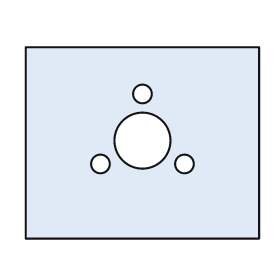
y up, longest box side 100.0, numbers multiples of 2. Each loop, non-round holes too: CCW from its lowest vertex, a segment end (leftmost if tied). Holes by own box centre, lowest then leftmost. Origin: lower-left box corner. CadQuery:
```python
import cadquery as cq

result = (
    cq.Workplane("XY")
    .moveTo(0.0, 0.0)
    .lineTo(100.0, 0.0)
    .lineTo(100.0, 82.0)
    .lineTo(0.0, 82.0)
    .close()
    .moveTo(32.0, 32.0)
    .circle(4.0)
    .moveTo(68.0, 32.0)
    .circle(4.0)
    .moveTo(50.0, 42.0)
    .circle(12.0)
    .moveTo(50.0, 62.0)
    .circle(4.0)
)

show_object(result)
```